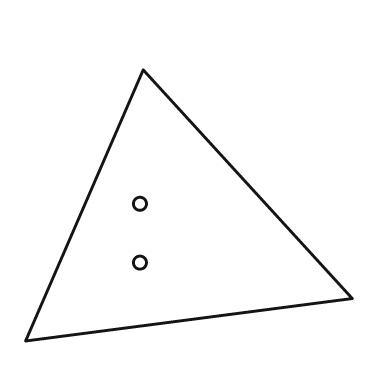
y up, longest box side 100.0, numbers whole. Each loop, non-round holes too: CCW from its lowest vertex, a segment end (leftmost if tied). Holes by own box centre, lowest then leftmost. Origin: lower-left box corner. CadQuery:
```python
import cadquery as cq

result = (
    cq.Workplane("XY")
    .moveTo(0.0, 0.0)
    .lineTo(100.0, 13.0)
    .lineTo(36.0, 83.0)
    .close()
    .moveTo(35.0, 24.0)
    .circle(2.0)
    .moveTo(35.0, 42.0)
    .circle(2.0)
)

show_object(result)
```